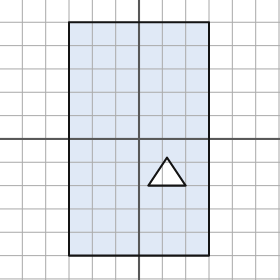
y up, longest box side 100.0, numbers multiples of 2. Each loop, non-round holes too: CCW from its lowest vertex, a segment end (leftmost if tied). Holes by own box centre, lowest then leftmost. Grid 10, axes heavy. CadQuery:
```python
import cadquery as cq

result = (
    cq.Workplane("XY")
    .moveTo(-30.0, -50.0)
    .lineTo(30.0, -50.0)
    .lineTo(30.0, 50.0)
    .lineTo(-30.0, 50.0)
    .close()
    .moveTo(4.0, -20.0)
    .lineTo(20.0, -20.0)
    .lineTo(12.0, -8.0)
    .close()
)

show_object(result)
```